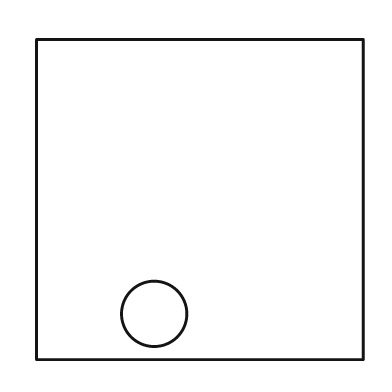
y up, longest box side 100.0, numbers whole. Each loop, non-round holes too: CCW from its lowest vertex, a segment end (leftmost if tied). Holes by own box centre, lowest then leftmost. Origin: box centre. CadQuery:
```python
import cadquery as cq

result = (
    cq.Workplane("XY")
    .moveTo(-50.0, -49.0)
    .lineTo(50.0, -49.0)
    .lineTo(50.0, 49.0)
    .lineTo(-50.0, 49.0)
    .close()
    .moveTo(-14.0, -35.0)
    .circle(10.0)
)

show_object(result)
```